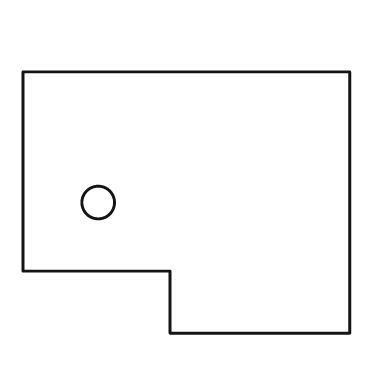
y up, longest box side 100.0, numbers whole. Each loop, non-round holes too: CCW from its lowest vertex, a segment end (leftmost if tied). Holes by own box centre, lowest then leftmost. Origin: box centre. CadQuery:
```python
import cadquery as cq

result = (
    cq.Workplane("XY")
    .moveTo(-5.0, -40.0)
    .lineTo(50.0, -40.0)
    .lineTo(50.0, 40.0)
    .lineTo(-50.0, 40.0)
    .lineTo(-50.0, -21.0)
    .lineTo(-5.0, -21.0)
    .close()
    .moveTo(-27.0, 0.0)
    .circle(5.0)
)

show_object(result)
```